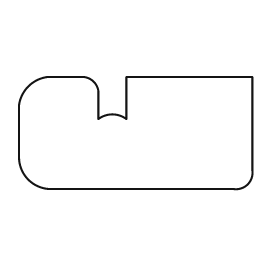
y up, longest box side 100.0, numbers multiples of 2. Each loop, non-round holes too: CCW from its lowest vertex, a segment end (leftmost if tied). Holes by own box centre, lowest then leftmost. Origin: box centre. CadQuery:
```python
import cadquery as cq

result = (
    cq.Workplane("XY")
    .moveTo(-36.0, -24.0)
    .lineTo(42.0, -24.0)
    .threePointArc((48.0, -22.0), (50.0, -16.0))
    .lineTo(50.0, 24.0)
    .lineTo(-4.0, 24.0)
    .lineTo(-4.0, 6.0)
    .threePointArc((-10.0, 8.0), (-16.0, 6.0))
    .lineTo(-16.0, 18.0)
    .threePointArc((-18.0, 22.0), (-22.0, 24.0))
    .lineTo(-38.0, 24.0)
    .threePointArc((-46.0, 20.0), (-50.0, 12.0))
    .lineTo(-50.0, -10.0)
    .threePointArc((-46.0, -20.0), (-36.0, -24.0))
    .close()
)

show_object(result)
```